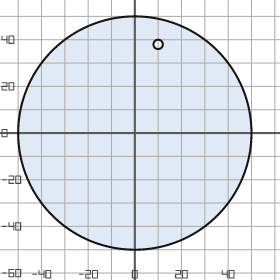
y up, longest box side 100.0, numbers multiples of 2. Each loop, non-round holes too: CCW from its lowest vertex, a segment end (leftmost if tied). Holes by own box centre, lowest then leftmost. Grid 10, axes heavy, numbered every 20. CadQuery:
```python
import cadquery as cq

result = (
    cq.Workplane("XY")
    .moveTo(0.0, 0.0)
    .circle(50.0)
    .moveTo(10.0, 38.0)
    .circle(2.0)
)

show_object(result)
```